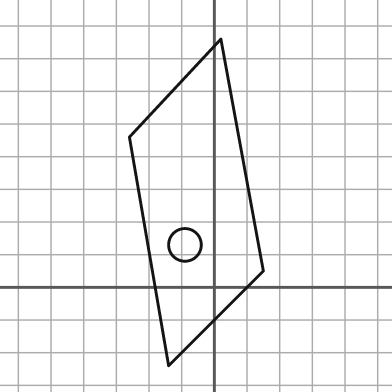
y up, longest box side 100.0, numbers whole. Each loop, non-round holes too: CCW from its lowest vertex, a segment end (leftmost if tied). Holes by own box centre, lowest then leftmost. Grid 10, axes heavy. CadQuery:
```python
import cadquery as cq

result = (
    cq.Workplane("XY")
    .moveTo(-14.0, -24.0)
    .lineTo(15.0, 5.0)
    .lineTo(2.0, 76.0)
    .lineTo(-26.0, 46.0)
    .close()
    .moveTo(-9.0, 13.0)
    .circle(5.0)
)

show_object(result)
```